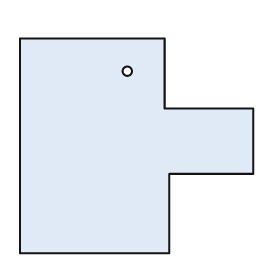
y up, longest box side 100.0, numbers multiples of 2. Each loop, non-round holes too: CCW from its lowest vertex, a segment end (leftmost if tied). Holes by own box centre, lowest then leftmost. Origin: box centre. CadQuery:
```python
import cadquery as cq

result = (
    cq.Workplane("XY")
    .moveTo(-50.0, -46.0)
    .lineTo(14.0, -46.0)
    .lineTo(14.0, -12.0)
    .lineTo(50.0, -12.0)
    .lineTo(50.0, 16.0)
    .lineTo(12.0, 16.0)
    .lineTo(12.0, 46.0)
    .lineTo(-50.0, 46.0)
    .close()
    .moveTo(-4.0, 32.0)
    .circle(2.0)
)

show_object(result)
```